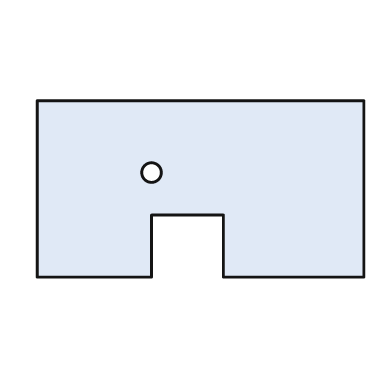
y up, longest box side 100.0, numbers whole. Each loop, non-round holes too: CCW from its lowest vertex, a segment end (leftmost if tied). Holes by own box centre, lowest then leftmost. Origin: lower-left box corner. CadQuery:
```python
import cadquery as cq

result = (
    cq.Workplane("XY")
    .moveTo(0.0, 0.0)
    .lineTo(35.0, 0.0)
    .lineTo(35.0, 19.0)
    .lineTo(57.0, 19.0)
    .lineTo(57.0, 0.0)
    .lineTo(100.0, 0.0)
    .lineTo(100.0, 54.0)
    .lineTo(0.0, 54.0)
    .close()
    .moveTo(35.0, 32.0)
    .circle(3.0)
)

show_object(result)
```